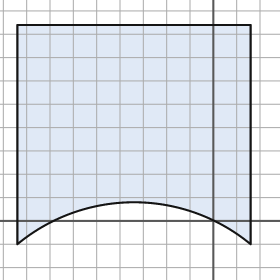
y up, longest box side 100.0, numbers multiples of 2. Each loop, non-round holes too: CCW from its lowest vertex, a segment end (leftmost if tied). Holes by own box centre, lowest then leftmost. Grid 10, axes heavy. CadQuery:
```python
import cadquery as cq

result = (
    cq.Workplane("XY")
    .moveTo(-84.0, -10.0)
    .threePointArc((-34.0, 8.0), (16.0, -10.0))
    .lineTo(16.0, 84.0)
    .lineTo(-84.0, 84.0)
    .close()
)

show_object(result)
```